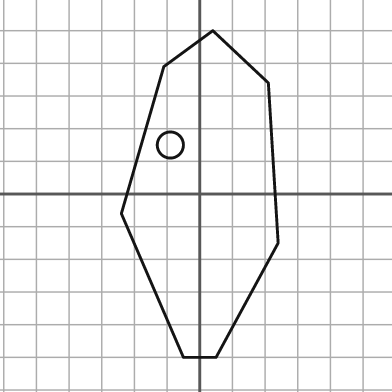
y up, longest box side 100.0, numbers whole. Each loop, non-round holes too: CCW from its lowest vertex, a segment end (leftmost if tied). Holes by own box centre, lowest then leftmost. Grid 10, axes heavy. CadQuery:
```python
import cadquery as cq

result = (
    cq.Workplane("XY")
    .moveTo(-5.0, -50.0)
    .lineTo(5.0, -50.0)
    .lineTo(24.0, -15.0)
    .lineTo(21.0, 34.0)
    .lineTo(4.0, 50.0)
    .lineTo(-11.0, 39.0)
    .lineTo(-24.0, -6.0)
    .close()
    .moveTo(-9.0, 15.0)
    .circle(4.0)
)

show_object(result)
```